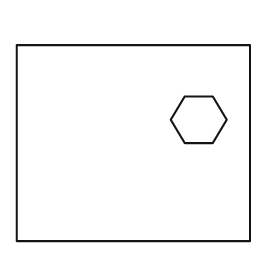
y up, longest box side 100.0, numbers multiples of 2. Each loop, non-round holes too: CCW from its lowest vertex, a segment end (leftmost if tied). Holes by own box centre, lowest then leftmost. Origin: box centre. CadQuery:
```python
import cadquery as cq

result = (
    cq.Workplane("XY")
    .moveTo(-50.0, -42.0)
    .lineTo(50.0, -42.0)
    .lineTo(50.0, 42.0)
    .lineTo(-50.0, 42.0)
    .close()
    .moveTo(22.0, 0.0)
    .lineTo(34.0, 0.0)
    .lineTo(40.0, 10.0)
    .lineTo(34.0, 20.0)
    .lineTo(22.0, 20.0)
    .lineTo(16.0, 10.0)
    .close()
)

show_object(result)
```